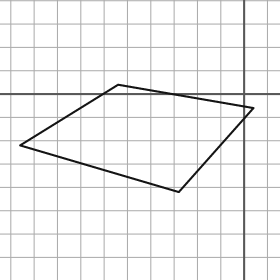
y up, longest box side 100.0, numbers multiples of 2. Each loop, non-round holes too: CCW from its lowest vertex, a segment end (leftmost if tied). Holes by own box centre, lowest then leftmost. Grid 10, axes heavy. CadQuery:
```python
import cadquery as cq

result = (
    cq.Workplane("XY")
    .moveTo(-28.0, -42.0)
    .lineTo(4.0, -6.0)
    .lineTo(-54.0, 4.0)
    .lineTo(-96.0, -22.0)
    .close()
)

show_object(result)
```